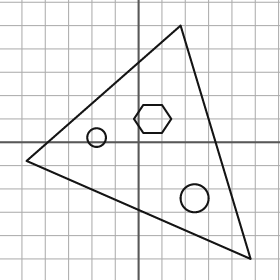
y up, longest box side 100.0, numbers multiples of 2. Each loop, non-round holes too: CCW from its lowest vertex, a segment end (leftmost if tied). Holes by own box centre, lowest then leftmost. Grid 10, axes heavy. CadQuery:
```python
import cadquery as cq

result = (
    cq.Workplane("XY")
    .moveTo(48.0, -50.0)
    .lineTo(18.0, 50.0)
    .lineTo(-48.0, -8.0)
    .close()
    .moveTo(24.0, -24.0)
    .circle(6.0)
    .moveTo(-18.0, 2.0)
    .circle(4.0)
    .moveTo(2.0, 4.0)
    .lineTo(10.0, 4.0)
    .lineTo(14.0, 10.0)
    .lineTo(10.0, 16.0)
    .lineTo(2.0, 16.0)
    .lineTo(-2.0, 10.0)
    .close()
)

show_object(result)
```